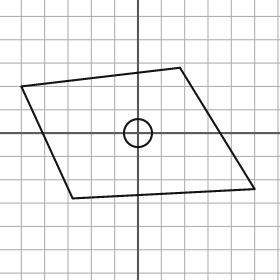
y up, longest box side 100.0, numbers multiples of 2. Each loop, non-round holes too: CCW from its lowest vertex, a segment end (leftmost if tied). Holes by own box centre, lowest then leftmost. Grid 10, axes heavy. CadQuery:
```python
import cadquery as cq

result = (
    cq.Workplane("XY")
    .moveTo(-28.0, -28.0)
    .lineTo(50.0, -24.0)
    .lineTo(18.0, 28.0)
    .lineTo(-50.0, 20.0)
    .close()
    .moveTo(0.0, 0.0)
    .circle(6.0)
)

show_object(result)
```